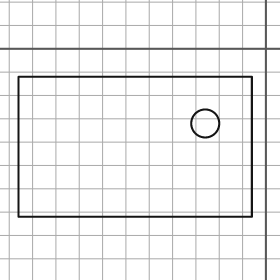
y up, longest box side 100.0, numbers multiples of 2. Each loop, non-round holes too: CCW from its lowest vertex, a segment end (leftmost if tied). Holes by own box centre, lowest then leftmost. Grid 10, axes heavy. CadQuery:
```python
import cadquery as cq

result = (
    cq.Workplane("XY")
    .moveTo(-106.0, -72.0)
    .lineTo(-6.0, -72.0)
    .lineTo(-6.0, -12.0)
    .lineTo(-106.0, -12.0)
    .close()
    .moveTo(-26.0, -32.0)
    .circle(6.0)
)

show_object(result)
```